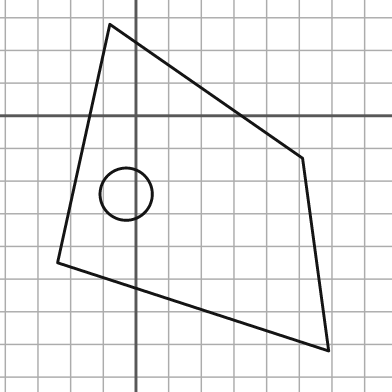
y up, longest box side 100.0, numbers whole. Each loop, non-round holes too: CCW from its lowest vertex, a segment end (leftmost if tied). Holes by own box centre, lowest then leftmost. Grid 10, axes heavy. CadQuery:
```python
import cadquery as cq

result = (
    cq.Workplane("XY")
    .moveTo(59.0, -72.0)
    .lineTo(51.0, -13.0)
    .lineTo(-8.0, 28.0)
    .lineTo(-24.0, -45.0)
    .close()
    .moveTo(-3.0, -24.0)
    .circle(8.0)
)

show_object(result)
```